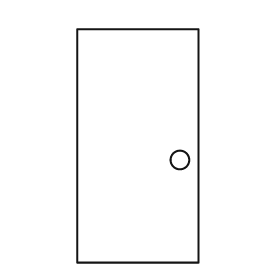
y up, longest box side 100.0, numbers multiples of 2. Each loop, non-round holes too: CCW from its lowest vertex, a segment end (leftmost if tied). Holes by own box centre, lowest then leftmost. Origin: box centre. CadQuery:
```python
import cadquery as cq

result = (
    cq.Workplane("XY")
    .moveTo(-26.0, -50.0)
    .lineTo(26.0, -50.0)
    .lineTo(26.0, 50.0)
    .lineTo(-26.0, 50.0)
    .close()
    .moveTo(18.0, -6.0)
    .circle(4.0)
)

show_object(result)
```